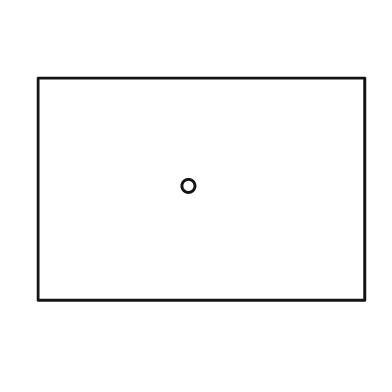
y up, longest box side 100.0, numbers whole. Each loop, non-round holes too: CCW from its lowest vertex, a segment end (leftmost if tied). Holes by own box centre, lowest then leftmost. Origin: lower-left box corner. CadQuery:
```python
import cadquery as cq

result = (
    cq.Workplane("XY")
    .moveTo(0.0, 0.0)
    .lineTo(100.0, 0.0)
    .lineTo(100.0, 68.0)
    .lineTo(0.0, 68.0)
    .close()
    .moveTo(46.0, 35.0)
    .circle(2.0)
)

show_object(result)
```